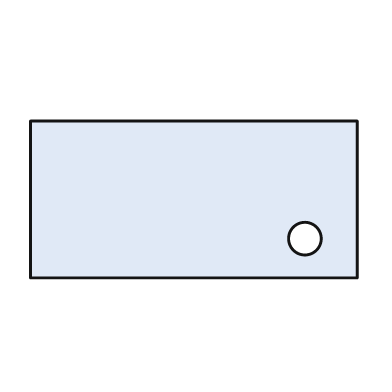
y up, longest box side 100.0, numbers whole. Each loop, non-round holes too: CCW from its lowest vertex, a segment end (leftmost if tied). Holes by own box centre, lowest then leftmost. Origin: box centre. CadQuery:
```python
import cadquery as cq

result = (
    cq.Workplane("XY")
    .moveTo(-50.0, -24.0)
    .lineTo(50.0, -24.0)
    .lineTo(50.0, 24.0)
    .lineTo(-50.0, 24.0)
    .close()
    .moveTo(34.0, -12.0)
    .circle(5.0)
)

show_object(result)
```